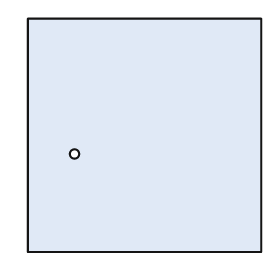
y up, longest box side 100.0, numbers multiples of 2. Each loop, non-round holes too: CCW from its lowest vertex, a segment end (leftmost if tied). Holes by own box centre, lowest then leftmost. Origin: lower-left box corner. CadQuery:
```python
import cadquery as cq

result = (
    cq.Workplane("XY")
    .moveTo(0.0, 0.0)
    .lineTo(100.0, 0.0)
    .lineTo(100.0, 100.0)
    .lineTo(0.0, 100.0)
    .close()
    .moveTo(20.0, 42.0)
    .circle(2.0)
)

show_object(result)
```